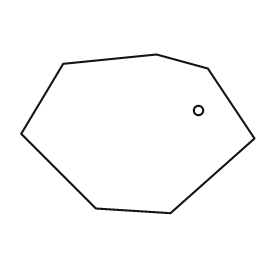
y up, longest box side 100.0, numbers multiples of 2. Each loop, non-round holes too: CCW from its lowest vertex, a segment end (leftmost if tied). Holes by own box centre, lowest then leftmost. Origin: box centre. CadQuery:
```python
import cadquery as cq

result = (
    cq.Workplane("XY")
    .moveTo(14.0, -34.0)
    .lineTo(50.0, -2.0)
    .lineTo(30.0, 28.0)
    .lineTo(8.0, 34.0)
    .lineTo(-32.0, 30.0)
    .lineTo(-50.0, 0.0)
    .lineTo(-18.0, -32.0)
    .close()
    .moveTo(26.0, 10.0)
    .circle(2.0)
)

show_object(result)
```